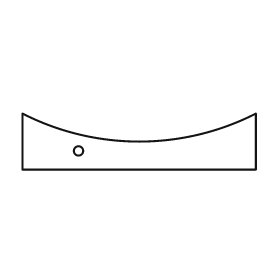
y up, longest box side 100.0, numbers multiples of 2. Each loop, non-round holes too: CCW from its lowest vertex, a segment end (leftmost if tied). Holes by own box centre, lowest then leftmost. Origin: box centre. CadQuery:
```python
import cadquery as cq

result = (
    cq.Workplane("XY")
    .moveTo(-50.0, -12.0)
    .lineTo(50.0, -12.0)
    .lineTo(50.0, 12.0)
    .threePointArc((0.0, 0.0), (-50.0, 12.0))
    .close()
    .moveTo(-26.0, -4.0)
    .circle(2.0)
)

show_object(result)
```